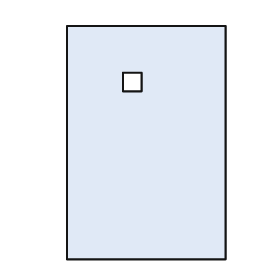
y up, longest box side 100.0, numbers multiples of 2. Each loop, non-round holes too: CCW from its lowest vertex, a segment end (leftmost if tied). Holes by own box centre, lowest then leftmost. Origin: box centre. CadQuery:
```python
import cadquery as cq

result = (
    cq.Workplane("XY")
    .moveTo(-34.0, -50.0)
    .lineTo(34.0, -50.0)
    .lineTo(34.0, 50.0)
    .lineTo(-34.0, 50.0)
    .close()
    .moveTo(-10.0, 22.0)
    .lineTo(-2.0, 22.0)
    .lineTo(-2.0, 30.0)
    .lineTo(-10.0, 30.0)
    .close()
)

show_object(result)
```